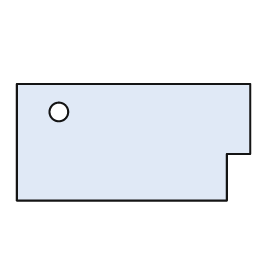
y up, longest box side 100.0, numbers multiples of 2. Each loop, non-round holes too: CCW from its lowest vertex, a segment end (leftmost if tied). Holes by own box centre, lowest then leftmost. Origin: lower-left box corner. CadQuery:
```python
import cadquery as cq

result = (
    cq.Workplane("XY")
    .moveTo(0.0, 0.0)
    .lineTo(90.0, 0.0)
    .lineTo(90.0, 20.0)
    .lineTo(100.0, 20.0)
    .lineTo(100.0, 50.0)
    .lineTo(0.0, 50.0)
    .close()
    .moveTo(18.0, 38.0)
    .circle(4.0)
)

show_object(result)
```